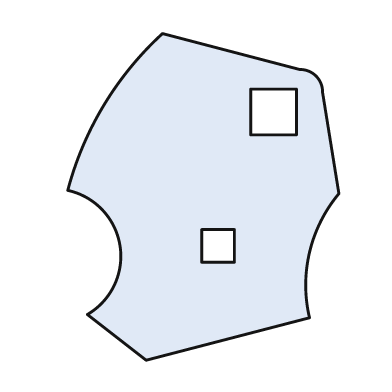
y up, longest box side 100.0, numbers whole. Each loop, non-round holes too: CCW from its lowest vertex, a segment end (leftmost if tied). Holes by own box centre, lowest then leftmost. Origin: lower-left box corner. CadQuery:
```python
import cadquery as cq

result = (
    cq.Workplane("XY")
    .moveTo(24.0, 0.0)
    .lineTo(74.0, 13.0)
    .threePointArc((74.0, 33.0), (83.0, 51.0))
    .lineTo(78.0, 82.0)
    .threePointArc((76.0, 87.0), (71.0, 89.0))
    .lineTo(29.0, 100.0)
    .threePointArc((11.0, 78.0), (0.0, 52.0))
    .threePointArc((16.0, 35.0), (6.0, 14.0))
    .close()
    .moveTo(41.0, 30.0)
    .lineTo(51.0, 30.0)
    .lineTo(51.0, 40.0)
    .lineTo(41.0, 40.0)
    .close()
    .moveTo(56.0, 69.0)
    .lineTo(70.0, 69.0)
    .lineTo(70.0, 83.0)
    .lineTo(56.0, 83.0)
    .close()
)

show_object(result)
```